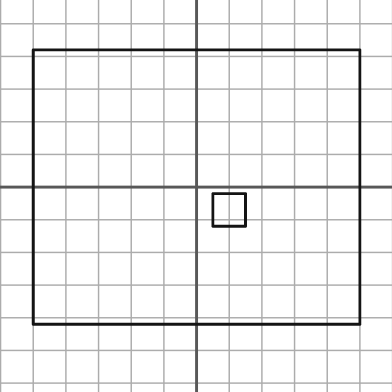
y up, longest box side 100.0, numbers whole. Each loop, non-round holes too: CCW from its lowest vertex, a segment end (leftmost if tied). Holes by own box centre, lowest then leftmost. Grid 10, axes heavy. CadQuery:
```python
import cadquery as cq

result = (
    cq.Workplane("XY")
    .moveTo(-50.0, -42.0)
    .lineTo(50.0, -42.0)
    .lineTo(50.0, 42.0)
    .lineTo(-50.0, 42.0)
    .close()
    .moveTo(5.0, -12.0)
    .lineTo(15.0, -12.0)
    .lineTo(15.0, -2.0)
    .lineTo(5.0, -2.0)
    .close()
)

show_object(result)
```